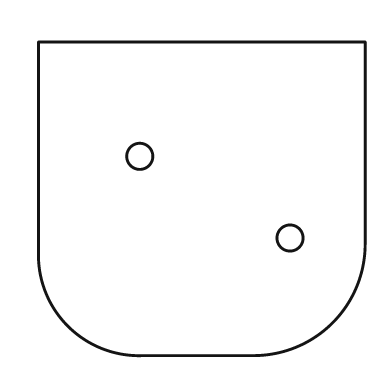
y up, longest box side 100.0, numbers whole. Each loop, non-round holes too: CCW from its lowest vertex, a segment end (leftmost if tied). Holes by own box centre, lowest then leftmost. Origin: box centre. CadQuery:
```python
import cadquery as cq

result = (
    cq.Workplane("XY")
    .moveTo(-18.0, -48.0)
    .lineTo(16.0, -48.0)
    .threePointArc((40.0, -38.0), (50.0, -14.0))
    .lineTo(50.0, 48.0)
    .lineTo(-50.0, 48.0)
    .lineTo(-50.0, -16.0)
    .threePointArc((-41.0, -39.0), (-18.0, -48.0))
    .close()
    .moveTo(27.0, -12.0)
    .circle(4.0)
    .moveTo(-19.0, 13.0)
    .circle(4.0)
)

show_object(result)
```